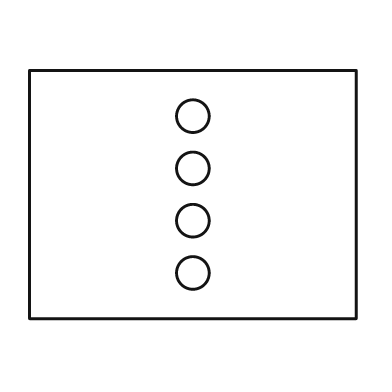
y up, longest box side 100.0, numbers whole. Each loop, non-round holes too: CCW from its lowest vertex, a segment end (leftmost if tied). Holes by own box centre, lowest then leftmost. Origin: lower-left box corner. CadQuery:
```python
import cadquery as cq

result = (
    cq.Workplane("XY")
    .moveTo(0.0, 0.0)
    .lineTo(100.0, 0.0)
    .lineTo(100.0, 76.0)
    .lineTo(0.0, 76.0)
    .close()
    .moveTo(50.0, 14.0)
    .circle(5.0)
    .moveTo(50.0, 30.0)
    .circle(5.0)
    .moveTo(50.0, 46.0)
    .circle(5.0)
    .moveTo(50.0, 62.0)
    .circle(5.0)
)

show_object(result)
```